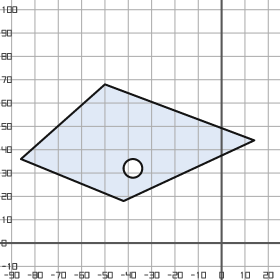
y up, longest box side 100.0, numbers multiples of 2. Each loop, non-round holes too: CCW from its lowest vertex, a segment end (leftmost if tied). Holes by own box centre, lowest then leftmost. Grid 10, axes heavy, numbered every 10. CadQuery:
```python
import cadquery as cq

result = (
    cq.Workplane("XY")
    .moveTo(-42.0, 18.0)
    .lineTo(14.0, 44.0)
    .lineTo(-50.0, 68.0)
    .lineTo(-86.0, 36.0)
    .close()
    .moveTo(-38.0, 32.0)
    .circle(4.0)
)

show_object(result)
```